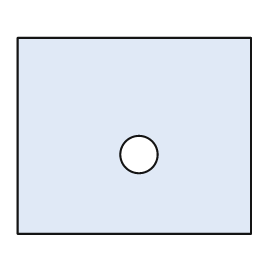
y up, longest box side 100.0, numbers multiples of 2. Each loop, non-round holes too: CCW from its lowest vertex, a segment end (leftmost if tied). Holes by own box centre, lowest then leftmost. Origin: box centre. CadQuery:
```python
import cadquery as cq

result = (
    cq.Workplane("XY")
    .moveTo(-50.0, -42.0)
    .lineTo(50.0, -42.0)
    .lineTo(50.0, 42.0)
    .lineTo(-50.0, 42.0)
    .close()
    .moveTo(2.0, -8.0)
    .circle(8.0)
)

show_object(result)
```